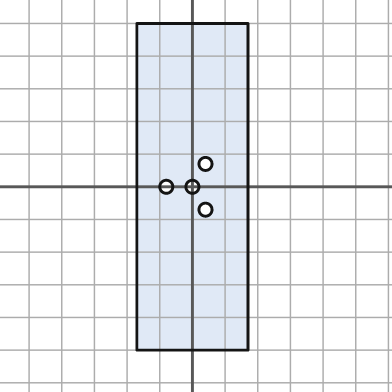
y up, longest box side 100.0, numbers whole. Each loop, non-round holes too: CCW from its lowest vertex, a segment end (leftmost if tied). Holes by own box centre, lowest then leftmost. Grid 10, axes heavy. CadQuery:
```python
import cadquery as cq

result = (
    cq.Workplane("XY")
    .moveTo(-17.0, -50.0)
    .lineTo(17.0, -50.0)
    .lineTo(17.0, 50.0)
    .lineTo(-17.0, 50.0)
    .close()
    .moveTo(4.0, -7.0)
    .circle(2.0)
    .moveTo(-8.0, 0.0)
    .circle(2.0)
    .moveTo(0.0, 0.0)
    .circle(2.0)
    .moveTo(4.0, 7.0)
    .circle(2.0)
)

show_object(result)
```